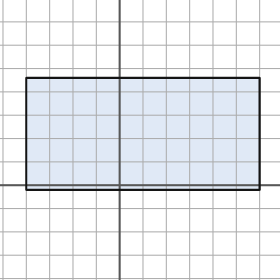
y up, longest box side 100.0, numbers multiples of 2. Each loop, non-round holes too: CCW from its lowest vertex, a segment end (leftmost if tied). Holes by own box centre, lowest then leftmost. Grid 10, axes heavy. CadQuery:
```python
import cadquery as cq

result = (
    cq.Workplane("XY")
    .moveTo(-40.0, -2.0)
    .lineTo(60.0, -2.0)
    .lineTo(60.0, 46.0)
    .lineTo(-40.0, 46.0)
    .close()
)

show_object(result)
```